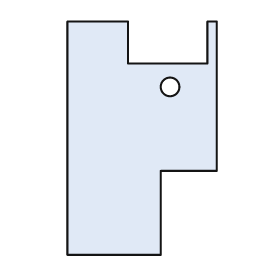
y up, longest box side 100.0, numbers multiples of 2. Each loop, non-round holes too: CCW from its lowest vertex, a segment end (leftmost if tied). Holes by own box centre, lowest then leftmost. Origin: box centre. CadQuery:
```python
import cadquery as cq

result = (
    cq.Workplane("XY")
    .moveTo(-32.0, -50.0)
    .lineTo(8.0, -50.0)
    .lineTo(8.0, -14.0)
    .lineTo(32.0, -14.0)
    .lineTo(32.0, 50.0)
    .lineTo(28.0, 50.0)
    .lineTo(28.0, 32.0)
    .lineTo(-6.0, 32.0)
    .lineTo(-6.0, 50.0)
    .lineTo(-32.0, 50.0)
    .close()
    .moveTo(12.0, 22.0)
    .circle(4.0)
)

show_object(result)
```